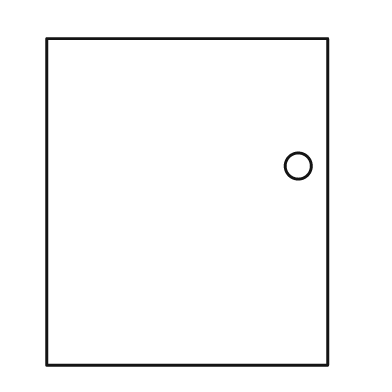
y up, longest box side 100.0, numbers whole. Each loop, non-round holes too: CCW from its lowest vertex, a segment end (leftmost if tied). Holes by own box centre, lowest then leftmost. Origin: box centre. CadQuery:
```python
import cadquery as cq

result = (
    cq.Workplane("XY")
    .moveTo(-43.0, -50.0)
    .lineTo(43.0, -50.0)
    .lineTo(43.0, 50.0)
    .lineTo(-43.0, 50.0)
    .close()
    .moveTo(34.0, 11.0)
    .circle(4.0)
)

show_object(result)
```